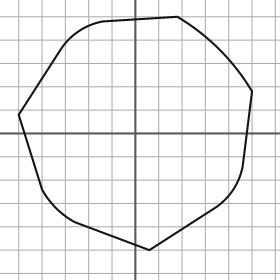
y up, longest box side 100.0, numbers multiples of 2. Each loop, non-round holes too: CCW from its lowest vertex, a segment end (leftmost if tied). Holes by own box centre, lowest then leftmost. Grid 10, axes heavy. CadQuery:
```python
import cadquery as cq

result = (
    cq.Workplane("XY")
    .moveTo(6.0, -50.0)
    .lineTo(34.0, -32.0)
    .threePointArc((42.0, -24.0), (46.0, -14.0))
    .lineTo(50.0, 18.0)
    .threePointArc((36.0, 36.0), (18.0, 50.0))
    .lineTo(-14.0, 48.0)
    .threePointArc((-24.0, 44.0), (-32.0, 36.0))
    .lineTo(-50.0, 8.0)
    .lineTo(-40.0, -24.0)
    .threePointArc((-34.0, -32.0), (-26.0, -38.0))
    .close()
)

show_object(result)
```